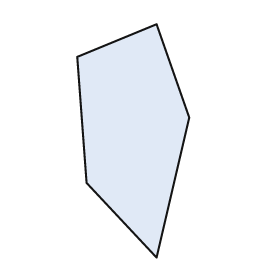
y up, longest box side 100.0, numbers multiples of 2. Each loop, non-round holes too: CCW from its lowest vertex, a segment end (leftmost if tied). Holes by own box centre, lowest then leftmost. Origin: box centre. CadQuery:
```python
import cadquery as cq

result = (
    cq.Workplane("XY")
    .moveTo(10.0, -50.0)
    .lineTo(24.0, 10.0)
    .lineTo(10.0, 50.0)
    .lineTo(-24.0, 36.0)
    .lineTo(-20.0, -18.0)
    .close()
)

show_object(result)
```